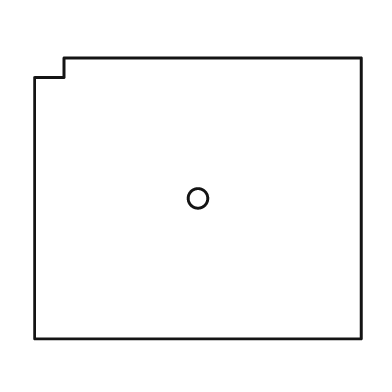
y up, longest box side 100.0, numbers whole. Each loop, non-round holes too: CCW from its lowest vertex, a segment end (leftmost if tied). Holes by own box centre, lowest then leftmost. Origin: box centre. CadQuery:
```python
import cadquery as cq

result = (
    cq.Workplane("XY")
    .moveTo(-50.0, -43.0)
    .lineTo(50.0, -43.0)
    .lineTo(50.0, 43.0)
    .lineTo(-41.0, 43.0)
    .lineTo(-41.0, 37.0)
    .lineTo(-50.0, 37.0)
    .close()
    .moveTo(0.0, 0.0)
    .circle(3.0)
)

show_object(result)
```